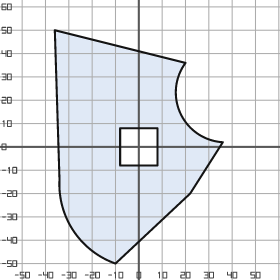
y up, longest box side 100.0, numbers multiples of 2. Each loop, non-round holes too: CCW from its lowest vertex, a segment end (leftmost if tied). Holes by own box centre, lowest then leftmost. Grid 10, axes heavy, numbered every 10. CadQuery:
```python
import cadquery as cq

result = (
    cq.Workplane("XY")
    .moveTo(-10.0, -50.0)
    .lineTo(22.0, -20.0)
    .lineTo(36.0, 2.0)
    .threePointArc((18.0, 14.0), (20.0, 36.0))
    .lineTo(-36.0, 50.0)
    .lineTo(-34.0, -14.0)
    .threePointArc((-28.0, -36.0), (-10.0, -50.0))
    .close()
    .moveTo(-8.0, -8.0)
    .lineTo(8.0, -8.0)
    .lineTo(8.0, 8.0)
    .lineTo(-8.0, 8.0)
    .close()
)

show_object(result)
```